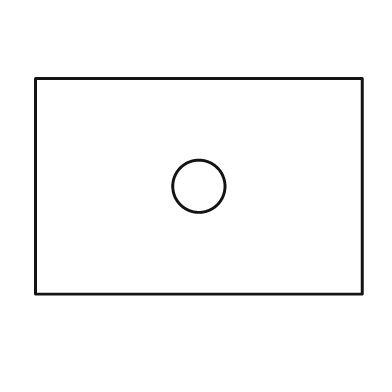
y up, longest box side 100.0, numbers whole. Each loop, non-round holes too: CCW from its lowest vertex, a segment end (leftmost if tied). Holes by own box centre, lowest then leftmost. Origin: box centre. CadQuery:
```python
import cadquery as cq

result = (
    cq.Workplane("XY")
    .moveTo(-50.0, -33.0)
    .lineTo(50.0, -33.0)
    .lineTo(50.0, 33.0)
    .lineTo(-50.0, 33.0)
    .close()
    .moveTo(0.0, 0.0)
    .circle(8.0)
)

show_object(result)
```